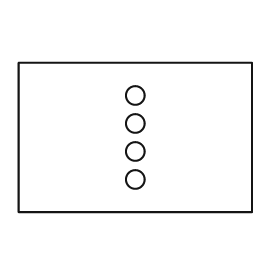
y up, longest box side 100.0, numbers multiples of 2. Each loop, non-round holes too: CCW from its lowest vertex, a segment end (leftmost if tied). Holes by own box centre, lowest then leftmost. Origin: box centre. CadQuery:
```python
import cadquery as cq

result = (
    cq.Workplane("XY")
    .moveTo(-50.0, -32.0)
    .lineTo(50.0, -32.0)
    .lineTo(50.0, 32.0)
    .lineTo(-50.0, 32.0)
    .close()
    .moveTo(0.0, -18.0)
    .circle(4.0)
    .moveTo(0.0, -6.0)
    .circle(4.0)
    .moveTo(0.0, 6.0)
    .circle(4.0)
    .moveTo(0.0, 18.0)
    .circle(4.0)
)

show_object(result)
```